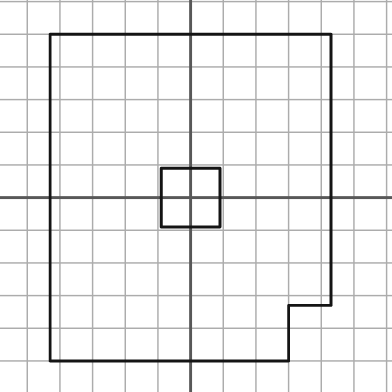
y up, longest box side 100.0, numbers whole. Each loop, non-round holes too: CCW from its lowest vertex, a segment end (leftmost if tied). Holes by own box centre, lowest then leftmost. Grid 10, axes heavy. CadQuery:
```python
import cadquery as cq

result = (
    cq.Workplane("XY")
    .moveTo(-43.0, -50.0)
    .lineTo(30.0, -50.0)
    .lineTo(30.0, -33.0)
    .lineTo(43.0, -33.0)
    .lineTo(43.0, 50.0)
    .lineTo(-43.0, 50.0)
    .close()
    .moveTo(-9.0, -9.0)
    .lineTo(9.0, -9.0)
    .lineTo(9.0, 9.0)
    .lineTo(-9.0, 9.0)
    .close()
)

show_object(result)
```